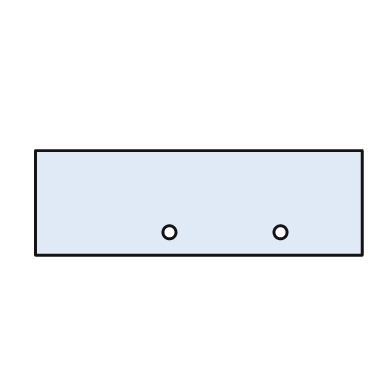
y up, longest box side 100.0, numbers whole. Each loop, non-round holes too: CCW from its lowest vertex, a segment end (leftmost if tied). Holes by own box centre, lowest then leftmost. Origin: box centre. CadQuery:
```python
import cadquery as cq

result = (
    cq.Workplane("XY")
    .moveTo(-50.0, -16.0)
    .lineTo(50.0, -16.0)
    .lineTo(50.0, 16.0)
    .lineTo(-50.0, 16.0)
    .close()
    .moveTo(-9.0, -9.0)
    .circle(2.0)
    .moveTo(25.0, -9.0)
    .circle(2.0)
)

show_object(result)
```